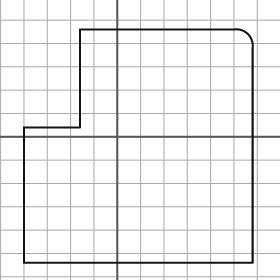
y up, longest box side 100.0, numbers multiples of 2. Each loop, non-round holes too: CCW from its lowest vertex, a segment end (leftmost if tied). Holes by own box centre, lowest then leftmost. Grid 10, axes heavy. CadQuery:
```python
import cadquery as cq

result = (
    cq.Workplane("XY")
    .moveTo(-40.0, -54.0)
    .lineTo(58.0, -54.0)
    .lineTo(58.0, 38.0)
    .threePointArc((56.0, 44.0), (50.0, 46.0))
    .lineTo(-16.0, 46.0)
    .lineTo(-16.0, 4.0)
    .lineTo(-40.0, 4.0)
    .close()
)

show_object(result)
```